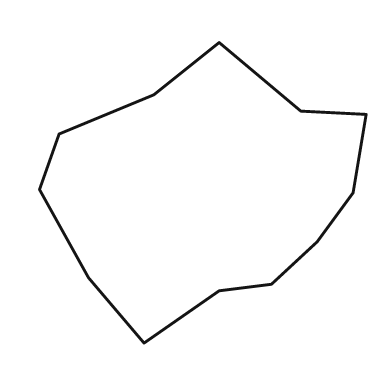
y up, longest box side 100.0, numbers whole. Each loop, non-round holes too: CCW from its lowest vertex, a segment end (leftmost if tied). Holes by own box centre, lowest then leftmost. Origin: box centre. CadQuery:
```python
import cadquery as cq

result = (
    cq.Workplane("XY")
    .moveTo(-18.0, -46.0)
    .lineTo(5.0, -30.0)
    .lineTo(21.0, -28.0)
    .lineTo(35.0, -15.0)
    .lineTo(46.0, 0.0)
    .lineTo(50.0, 24.0)
    .lineTo(30.0, 25.0)
    .lineTo(5.0, 46.0)
    .lineTo(-15.0, 30.0)
    .lineTo(-44.0, 18.0)
    .lineTo(-50.0, 1.0)
    .lineTo(-35.0, -26.0)
    .close()
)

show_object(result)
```